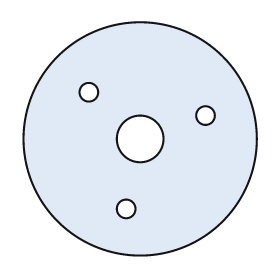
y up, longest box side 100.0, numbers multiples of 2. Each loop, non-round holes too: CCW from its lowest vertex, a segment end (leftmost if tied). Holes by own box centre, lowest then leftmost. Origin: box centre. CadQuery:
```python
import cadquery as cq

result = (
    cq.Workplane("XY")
    .moveTo(0.0, 0.0)
    .circle(50.0)
    .moveTo(-6.0, -30.0)
    .circle(4.0)
    .moveTo(0.0, 0.0)
    .circle(10.0)
    .moveTo(28.0, 10.0)
    .circle(4.0)
    .moveTo(-22.0, 20.0)
    .circle(4.0)
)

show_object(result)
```